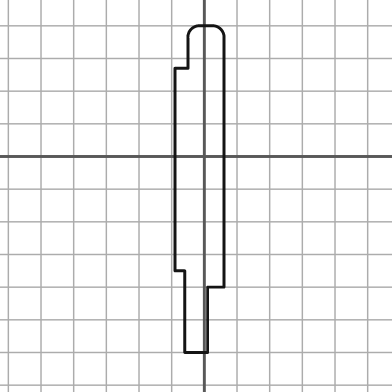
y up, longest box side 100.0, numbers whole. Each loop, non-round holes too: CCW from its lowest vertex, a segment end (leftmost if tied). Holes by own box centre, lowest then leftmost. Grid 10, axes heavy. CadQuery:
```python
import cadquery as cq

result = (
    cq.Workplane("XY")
    .moveTo(-6.0, -60.0)
    .lineTo(1.0, -60.0)
    .lineTo(1.0, -40.0)
    .lineTo(6.0, -40.0)
    .lineTo(6.0, 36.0)
    .threePointArc((5.0, 39.0), (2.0, 40.0))
    .lineTo(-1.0, 40.0)
    .threePointArc((-4.0, 39.0), (-5.0, 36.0))
    .lineTo(-5.0, 27.0)
    .lineTo(-9.0, 27.0)
    .lineTo(-9.0, -35.0)
    .lineTo(-6.0, -35.0)
    .close()
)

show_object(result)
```